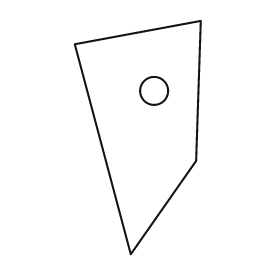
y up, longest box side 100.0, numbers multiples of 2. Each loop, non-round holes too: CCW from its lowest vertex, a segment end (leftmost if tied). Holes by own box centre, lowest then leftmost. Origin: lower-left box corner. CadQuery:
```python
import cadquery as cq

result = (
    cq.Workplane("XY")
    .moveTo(24.0, 0.0)
    .lineTo(52.0, 40.0)
    .lineTo(54.0, 100.0)
    .lineTo(0.0, 90.0)
    .close()
    .moveTo(34.0, 70.0)
    .circle(6.0)
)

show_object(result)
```